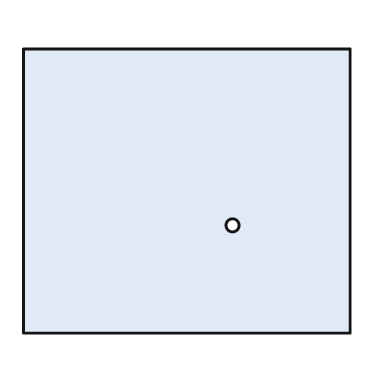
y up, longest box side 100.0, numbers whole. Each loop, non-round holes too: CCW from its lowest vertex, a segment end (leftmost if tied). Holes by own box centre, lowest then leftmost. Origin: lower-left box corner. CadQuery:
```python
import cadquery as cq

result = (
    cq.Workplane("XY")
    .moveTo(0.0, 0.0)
    .lineTo(100.0, 0.0)
    .lineTo(100.0, 87.0)
    .lineTo(0.0, 87.0)
    .close()
    .moveTo(64.0, 33.0)
    .circle(2.0)
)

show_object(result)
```